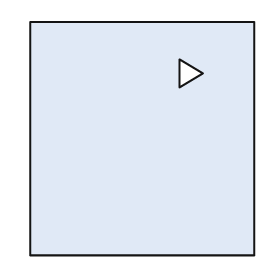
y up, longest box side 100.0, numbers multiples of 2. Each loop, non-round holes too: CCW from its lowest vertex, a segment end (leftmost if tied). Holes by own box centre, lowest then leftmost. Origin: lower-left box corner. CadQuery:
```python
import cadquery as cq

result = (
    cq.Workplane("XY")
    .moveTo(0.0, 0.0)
    .lineTo(96.0, 0.0)
    .lineTo(96.0, 100.0)
    .lineTo(0.0, 100.0)
    .close()
    .moveTo(64.0, 72.0)
    .lineTo(74.0, 78.0)
    .lineTo(64.0, 84.0)
    .close()
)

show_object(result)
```